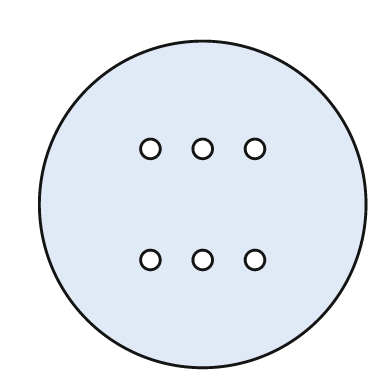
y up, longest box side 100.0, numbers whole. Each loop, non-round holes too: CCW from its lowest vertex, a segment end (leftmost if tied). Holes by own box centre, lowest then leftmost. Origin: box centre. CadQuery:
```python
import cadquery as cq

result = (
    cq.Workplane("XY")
    .moveTo(0.0, 0.0)
    .circle(50.0)
    .moveTo(-16.0, -17.0)
    .circle(3.0)
    .moveTo(0.0, -17.0)
    .circle(3.0)
    .moveTo(16.0, -17.0)
    .circle(3.0)
    .moveTo(-16.0, 17.0)
    .circle(3.0)
    .moveTo(0.0, 17.0)
    .circle(3.0)
    .moveTo(16.0, 17.0)
    .circle(3.0)
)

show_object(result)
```